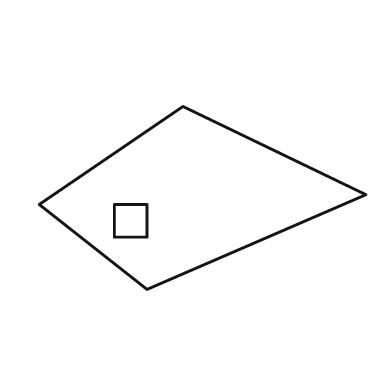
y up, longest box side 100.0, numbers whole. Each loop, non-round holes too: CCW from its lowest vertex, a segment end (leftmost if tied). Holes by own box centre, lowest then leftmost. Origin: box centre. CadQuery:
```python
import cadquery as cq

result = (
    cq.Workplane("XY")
    .moveTo(-17.0, -28.0)
    .lineTo(50.0, 1.0)
    .lineTo(-6.0, 28.0)
    .lineTo(-50.0, -2.0)
    .close()
    .moveTo(-27.0, -12.0)
    .lineTo(-17.0, -12.0)
    .lineTo(-17.0, -2.0)
    .lineTo(-27.0, -2.0)
    .close()
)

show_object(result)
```